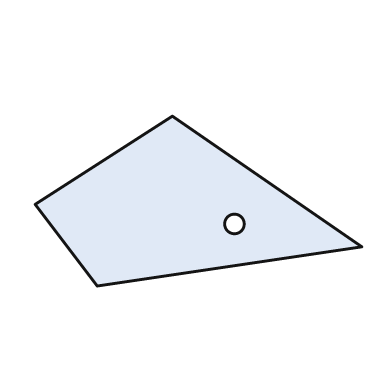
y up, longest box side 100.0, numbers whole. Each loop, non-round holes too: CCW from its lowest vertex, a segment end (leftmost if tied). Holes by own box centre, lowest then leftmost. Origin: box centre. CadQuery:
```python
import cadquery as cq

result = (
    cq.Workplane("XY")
    .moveTo(-31.0, -26.0)
    .lineTo(50.0, -14.0)
    .lineTo(-8.0, 26.0)
    .lineTo(-50.0, -1.0)
    .close()
    .moveTo(11.0, -7.0)
    .circle(3.0)
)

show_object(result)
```